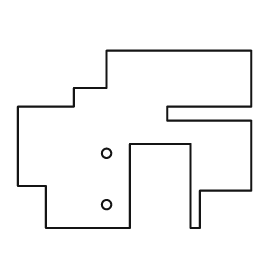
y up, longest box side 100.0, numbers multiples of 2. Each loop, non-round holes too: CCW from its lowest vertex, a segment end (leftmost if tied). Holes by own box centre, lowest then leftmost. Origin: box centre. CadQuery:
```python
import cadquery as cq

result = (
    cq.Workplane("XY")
    .moveTo(-38.0, -38.0)
    .lineTo(-2.0, -38.0)
    .lineTo(-2.0, -2.0)
    .lineTo(24.0, -2.0)
    .lineTo(24.0, -38.0)
    .lineTo(28.0, -38.0)
    .lineTo(28.0, -22.0)
    .lineTo(50.0, -22.0)
    .lineTo(50.0, 8.0)
    .lineTo(14.0, 8.0)
    .lineTo(14.0, 14.0)
    .lineTo(50.0, 14.0)
    .lineTo(50.0, 38.0)
    .lineTo(-12.0, 38.0)
    .lineTo(-12.0, 22.0)
    .lineTo(-26.0, 22.0)
    .lineTo(-26.0, 14.0)
    .lineTo(-50.0, 14.0)
    .lineTo(-50.0, -20.0)
    .lineTo(-38.0, -20.0)
    .close()
    .moveTo(-12.0, -28.0)
    .circle(2.0)
    .moveTo(-12.0, -6.0)
    .circle(2.0)
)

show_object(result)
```